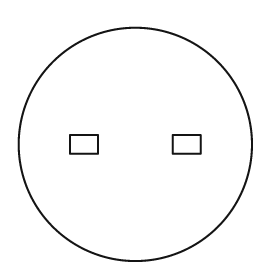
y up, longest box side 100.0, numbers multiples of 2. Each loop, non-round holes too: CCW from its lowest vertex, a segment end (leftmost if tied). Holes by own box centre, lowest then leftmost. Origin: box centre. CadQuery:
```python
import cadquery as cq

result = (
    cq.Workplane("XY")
    .moveTo(0.0, 0.0)
    .circle(50.0)
    .moveTo(-28.0, -4.0)
    .lineTo(-16.0, -4.0)
    .lineTo(-16.0, 4.0)
    .lineTo(-28.0, 4.0)
    .close()
    .moveTo(16.0, -4.0)
    .lineTo(28.0, -4.0)
    .lineTo(28.0, 4.0)
    .lineTo(16.0, 4.0)
    .close()
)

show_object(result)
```